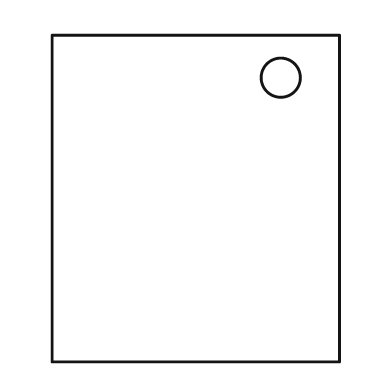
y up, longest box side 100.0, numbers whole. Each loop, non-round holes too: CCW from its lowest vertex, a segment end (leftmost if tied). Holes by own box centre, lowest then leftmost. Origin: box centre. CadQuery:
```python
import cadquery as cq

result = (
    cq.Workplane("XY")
    .moveTo(-44.0, -50.0)
    .lineTo(44.0, -50.0)
    .lineTo(44.0, 50.0)
    .lineTo(-44.0, 50.0)
    .close()
    .moveTo(26.0, 37.0)
    .circle(6.0)
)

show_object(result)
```